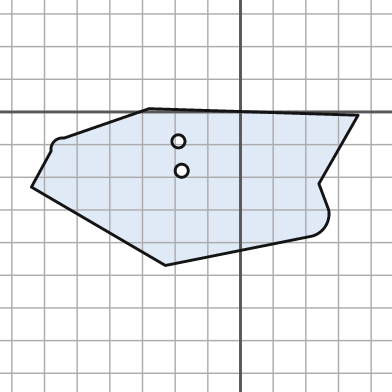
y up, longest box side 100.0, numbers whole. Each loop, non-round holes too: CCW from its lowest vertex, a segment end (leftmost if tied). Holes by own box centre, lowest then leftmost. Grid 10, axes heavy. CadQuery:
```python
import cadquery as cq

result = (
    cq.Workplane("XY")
    .moveTo(-23.0, -47.0)
    .lineTo(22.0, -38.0)
    .threePointArc((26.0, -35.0), (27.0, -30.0))
    .lineTo(24.0, -22.0)
    .lineTo(36.0, -1.0)
    .lineTo(-28.0, 1.0)
    .lineTo(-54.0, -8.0)
    .threePointArc((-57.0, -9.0), (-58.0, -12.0))
    .lineTo(-64.0, -23.0)
    .close()
    .moveTo(-18.0, -18.0)
    .circle(2.0)
    .moveTo(-19.0, -9.0)
    .circle(2.0)
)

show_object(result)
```